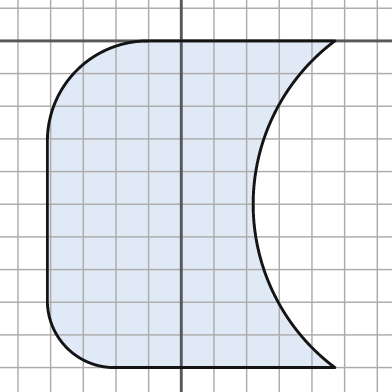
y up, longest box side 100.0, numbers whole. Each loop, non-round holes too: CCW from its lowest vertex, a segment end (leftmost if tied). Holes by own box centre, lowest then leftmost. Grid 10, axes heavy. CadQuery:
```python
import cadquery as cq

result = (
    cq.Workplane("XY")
    .moveTo(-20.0, -100.0)
    .lineTo(47.0, -100.0)
    .threePointArc((22.0, -50.0), (47.0, 0.0))
    .lineTo(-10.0, 0.0)
    .threePointArc((-32.0, -9.0), (-41.0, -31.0))
    .lineTo(-41.0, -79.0)
    .threePointArc((-35.0, -94.0), (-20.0, -100.0))
    .close()
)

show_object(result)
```